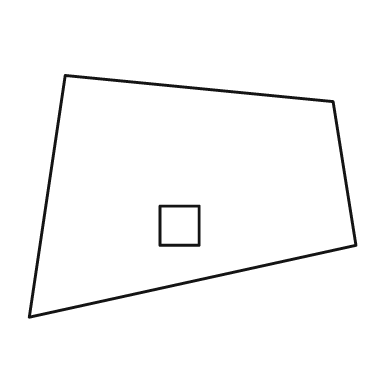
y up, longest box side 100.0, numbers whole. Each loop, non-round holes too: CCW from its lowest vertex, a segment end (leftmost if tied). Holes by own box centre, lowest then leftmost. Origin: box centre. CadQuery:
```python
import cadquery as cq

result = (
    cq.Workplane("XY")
    .moveTo(-50.0, -37.0)
    .lineTo(50.0, -15.0)
    .lineTo(43.0, 29.0)
    .lineTo(-39.0, 37.0)
    .close()
    .moveTo(-10.0, -15.0)
    .lineTo(2.0, -15.0)
    .lineTo(2.0, -3.0)
    .lineTo(-10.0, -3.0)
    .close()
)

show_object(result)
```